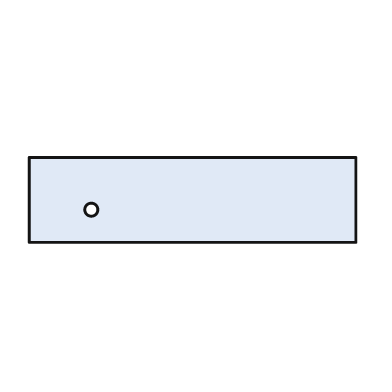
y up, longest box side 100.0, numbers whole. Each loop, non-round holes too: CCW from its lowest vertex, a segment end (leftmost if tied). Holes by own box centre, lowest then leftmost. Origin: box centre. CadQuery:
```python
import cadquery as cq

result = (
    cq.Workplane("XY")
    .moveTo(-50.0, -13.0)
    .lineTo(50.0, -13.0)
    .lineTo(50.0, 13.0)
    .lineTo(-50.0, 13.0)
    .close()
    .moveTo(-31.0, -3.0)
    .circle(2.0)
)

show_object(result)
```